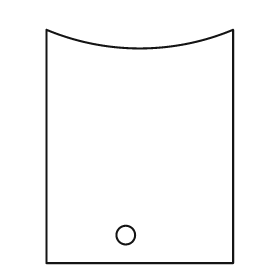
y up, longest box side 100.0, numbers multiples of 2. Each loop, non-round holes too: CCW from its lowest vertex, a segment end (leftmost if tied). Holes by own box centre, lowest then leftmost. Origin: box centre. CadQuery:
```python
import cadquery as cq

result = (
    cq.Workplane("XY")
    .moveTo(-40.0, -50.0)
    .lineTo(40.0, -50.0)
    .lineTo(40.0, 50.0)
    .threePointArc((0.0, 42.0), (-40.0, 50.0))
    .close()
    .moveTo(-6.0, -38.0)
    .circle(4.0)
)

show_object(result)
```